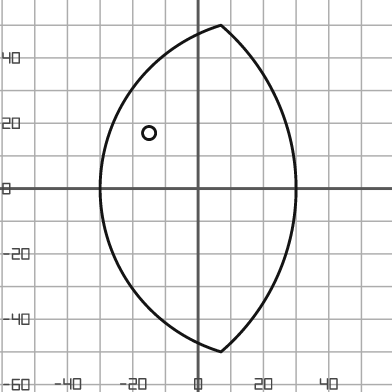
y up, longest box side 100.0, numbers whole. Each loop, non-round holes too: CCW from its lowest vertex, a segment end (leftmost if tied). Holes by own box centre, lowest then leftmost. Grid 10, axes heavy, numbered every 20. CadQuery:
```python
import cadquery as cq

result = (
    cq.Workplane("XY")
    .moveTo(7.0, -50.0)
    .threePointArc((30.0, 0.0), (7.0, 50.0))
    .threePointArc((-30.0, 0.0), (7.0, -50.0))
    .close()
    .moveTo(-15.0, 17.0)
    .circle(2.0)
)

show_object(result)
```